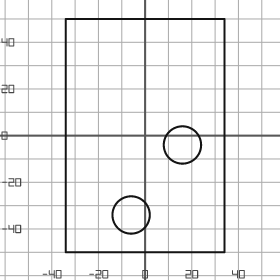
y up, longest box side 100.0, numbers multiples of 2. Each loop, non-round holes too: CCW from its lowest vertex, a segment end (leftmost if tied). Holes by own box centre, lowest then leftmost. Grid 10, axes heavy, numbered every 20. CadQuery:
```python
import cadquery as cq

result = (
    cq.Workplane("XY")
    .moveTo(-34.0, -50.0)
    .lineTo(34.0, -50.0)
    .lineTo(34.0, 50.0)
    .lineTo(-34.0, 50.0)
    .close()
    .moveTo(-6.0, -34.0)
    .circle(8.0)
    .moveTo(16.0, -4.0)
    .circle(8.0)
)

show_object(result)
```